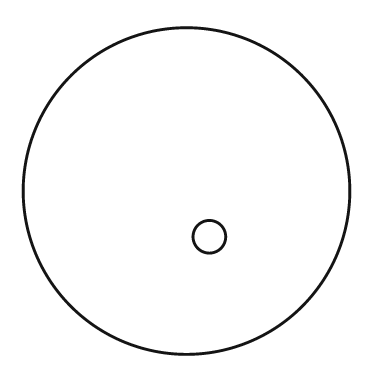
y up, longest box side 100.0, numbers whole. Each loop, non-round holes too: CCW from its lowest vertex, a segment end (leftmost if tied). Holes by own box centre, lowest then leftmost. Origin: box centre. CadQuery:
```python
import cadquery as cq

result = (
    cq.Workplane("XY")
    .moveTo(0.0, 0.0)
    .circle(50.0)
    .moveTo(7.0, -14.0)
    .circle(5.0)
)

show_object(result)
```